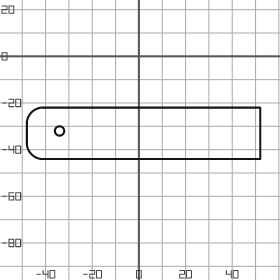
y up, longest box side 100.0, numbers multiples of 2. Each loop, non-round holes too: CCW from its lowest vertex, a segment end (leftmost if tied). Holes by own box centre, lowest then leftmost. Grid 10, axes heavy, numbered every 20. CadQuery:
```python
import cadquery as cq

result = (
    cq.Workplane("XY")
    .moveTo(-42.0, -44.0)
    .lineTo(52.0, -44.0)
    .lineTo(52.0, -22.0)
    .lineTo(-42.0, -22.0)
    .threePointArc((-46.0, -24.0), (-48.0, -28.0))
    .lineTo(-48.0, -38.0)
    .threePointArc((-46.0, -42.0), (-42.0, -44.0))
    .close()
    .moveTo(-34.0, -32.0)
    .circle(2.0)
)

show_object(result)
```